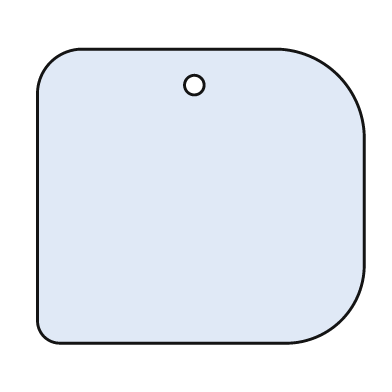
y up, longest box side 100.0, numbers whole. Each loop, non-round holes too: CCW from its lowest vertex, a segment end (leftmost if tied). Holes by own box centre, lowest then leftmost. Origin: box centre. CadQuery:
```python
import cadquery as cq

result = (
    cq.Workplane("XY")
    .moveTo(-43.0, -45.0)
    .lineTo(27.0, -45.0)
    .threePointArc((43.0, -38.0), (50.0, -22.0))
    .lineTo(50.0, 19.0)
    .threePointArc((42.0, 37.0), (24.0, 45.0))
    .lineTo(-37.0, 45.0)
    .threePointArc((-46.0, 41.0), (-50.0, 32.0))
    .lineTo(-50.0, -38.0)
    .threePointArc((-48.0, -43.0), (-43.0, -45.0))
    .close()
    .moveTo(-2.0, 34.0)
    .circle(3.0)
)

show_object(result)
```